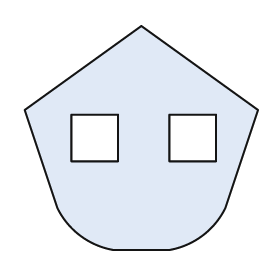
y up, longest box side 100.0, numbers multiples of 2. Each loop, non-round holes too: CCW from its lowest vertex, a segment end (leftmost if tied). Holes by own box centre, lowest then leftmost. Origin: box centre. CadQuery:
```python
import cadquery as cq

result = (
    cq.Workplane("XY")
    .moveTo(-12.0, -48.0)
    .lineTo(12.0, -48.0)
    .threePointArc((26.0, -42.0), (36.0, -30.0))
    .lineTo(50.0, 12.0)
    .lineTo(0.0, 48.0)
    .lineTo(-50.0, 12.0)
    .lineTo(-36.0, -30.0)
    .threePointArc((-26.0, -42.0), (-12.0, -48.0))
    .close()
    .moveTo(-30.0, -10.0)
    .lineTo(-10.0, -10.0)
    .lineTo(-10.0, 10.0)
    .lineTo(-30.0, 10.0)
    .close()
    .moveTo(12.0, -10.0)
    .lineTo(32.0, -10.0)
    .lineTo(32.0, 10.0)
    .lineTo(12.0, 10.0)
    .close()
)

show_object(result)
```